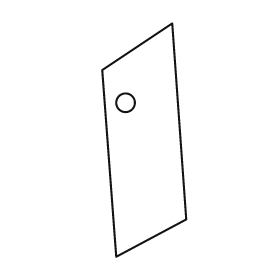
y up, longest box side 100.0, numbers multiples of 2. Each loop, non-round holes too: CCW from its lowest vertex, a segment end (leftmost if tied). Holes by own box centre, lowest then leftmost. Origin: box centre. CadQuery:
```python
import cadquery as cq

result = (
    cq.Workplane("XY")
    .moveTo(-12.0, -50.0)
    .lineTo(18.0, -34.0)
    .lineTo(12.0, 50.0)
    .lineTo(-18.0, 30.0)
    .close()
    .moveTo(-8.0, 16.0)
    .circle(4.0)
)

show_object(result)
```